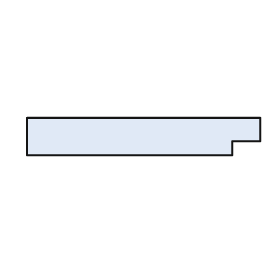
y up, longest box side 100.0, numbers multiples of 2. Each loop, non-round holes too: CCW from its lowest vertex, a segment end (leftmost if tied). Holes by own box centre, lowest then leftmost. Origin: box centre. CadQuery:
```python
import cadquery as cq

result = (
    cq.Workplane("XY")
    .moveTo(-50.0, -8.0)
    .lineTo(38.0, -8.0)
    .lineTo(38.0, -2.0)
    .lineTo(50.0, -2.0)
    .lineTo(50.0, 8.0)
    .lineTo(-50.0, 8.0)
    .close()
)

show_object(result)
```